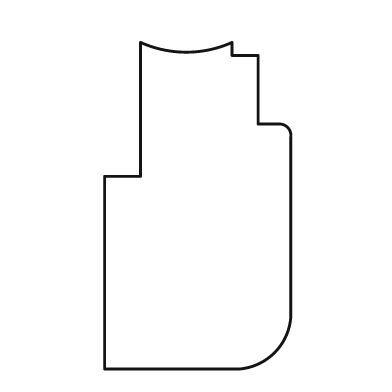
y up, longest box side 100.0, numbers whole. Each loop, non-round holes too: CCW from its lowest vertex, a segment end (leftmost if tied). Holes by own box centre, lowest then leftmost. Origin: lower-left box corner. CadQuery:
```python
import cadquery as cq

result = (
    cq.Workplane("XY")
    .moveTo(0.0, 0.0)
    .lineTo(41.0, 0.0)
    .threePointArc((52.0, 5.0), (57.0, 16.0))
    .lineTo(57.0, 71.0)
    .threePointArc((56.0, 74.0), (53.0, 75.0))
    .lineTo(47.0, 75.0)
    .lineTo(47.0, 96.0)
    .lineTo(39.0, 96.0)
    .lineTo(39.0, 100.0)
    .threePointArc((25.0, 97.0), (11.0, 100.0))
    .lineTo(11.0, 59.0)
    .lineTo(0.0, 59.0)
    .close()
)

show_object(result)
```